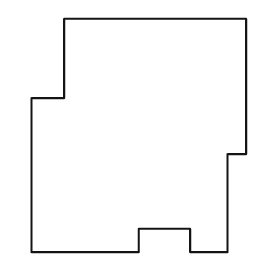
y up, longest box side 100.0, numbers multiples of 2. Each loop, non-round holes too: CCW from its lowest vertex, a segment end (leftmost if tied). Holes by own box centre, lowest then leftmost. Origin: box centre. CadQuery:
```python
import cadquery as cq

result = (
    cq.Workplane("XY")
    .moveTo(-46.0, -50.0)
    .lineTo(0.0, -50.0)
    .lineTo(0.0, -40.0)
    .lineTo(22.0, -40.0)
    .lineTo(22.0, -50.0)
    .lineTo(38.0, -50.0)
    .lineTo(38.0, -8.0)
    .lineTo(46.0, -8.0)
    .lineTo(46.0, 50.0)
    .lineTo(-32.0, 50.0)
    .lineTo(-32.0, 16.0)
    .lineTo(-46.0, 16.0)
    .close()
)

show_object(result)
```